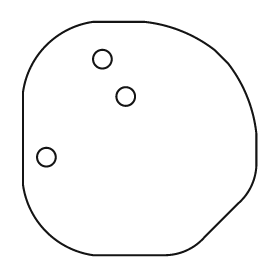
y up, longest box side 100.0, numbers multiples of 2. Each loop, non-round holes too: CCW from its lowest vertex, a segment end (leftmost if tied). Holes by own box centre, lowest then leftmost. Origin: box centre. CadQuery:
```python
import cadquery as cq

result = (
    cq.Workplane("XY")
    .moveTo(-20.0, -50.0)
    .lineTo(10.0, -50.0)
    .threePointArc((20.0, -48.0), (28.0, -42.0))
    .lineTo(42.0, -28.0)
    .threePointArc((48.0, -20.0), (50.0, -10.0))
    .lineTo(50.0, 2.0)
    .threePointArc((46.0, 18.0), (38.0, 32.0))
    .lineTo(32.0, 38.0)
    .threePointArc((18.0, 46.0), (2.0, 50.0))
    .lineTo(-20.0, 50.0)
    .threePointArc((-40.0, 40.0), (-50.0, 20.0))
    .lineTo(-50.0, -20.0)
    .threePointArc((-40.0, -40.0), (-20.0, -50.0))
    .close()
    .moveTo(-40.0, -8.0)
    .circle(4.0)
    .moveTo(-6.0, 18.0)
    .circle(4.0)
    .moveTo(-16.0, 34.0)
    .circle(4.0)
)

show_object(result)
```